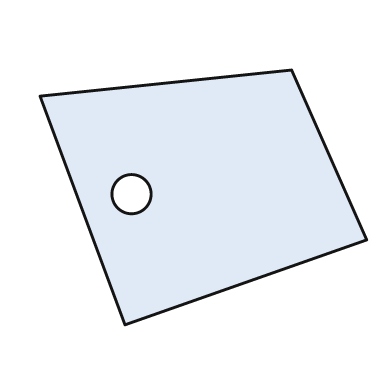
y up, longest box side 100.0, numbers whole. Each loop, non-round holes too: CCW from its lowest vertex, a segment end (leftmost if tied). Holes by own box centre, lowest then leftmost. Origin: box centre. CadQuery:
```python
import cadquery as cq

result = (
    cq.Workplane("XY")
    .moveTo(-24.0, -39.0)
    .lineTo(50.0, -13.0)
    .lineTo(27.0, 39.0)
    .lineTo(-50.0, 31.0)
    .close()
    .moveTo(-22.0, 1.0)
    .circle(6.0)
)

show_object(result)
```